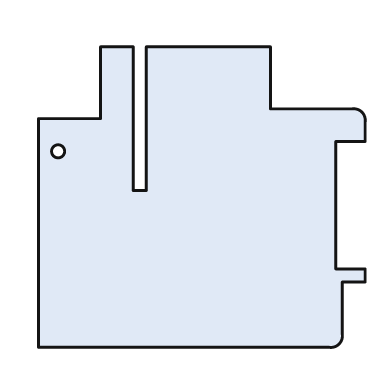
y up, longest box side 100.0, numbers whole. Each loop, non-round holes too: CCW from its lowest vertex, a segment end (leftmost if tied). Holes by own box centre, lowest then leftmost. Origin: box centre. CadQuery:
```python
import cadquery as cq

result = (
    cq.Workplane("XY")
    .moveTo(-50.0, -46.0)
    .lineTo(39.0, -46.0)
    .threePointArc((42.0, -45.0), (43.0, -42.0))
    .lineTo(43.0, -26.0)
    .lineTo(50.0, -26.0)
    .lineTo(50.0, -22.0)
    .lineTo(41.0, -22.0)
    .lineTo(41.0, 17.0)
    .lineTo(50.0, 17.0)
    .lineTo(50.0, 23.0)
    .threePointArc((49.0, 26.0), (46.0, 27.0))
    .lineTo(21.0, 27.0)
    .lineTo(21.0, 46.0)
    .lineTo(-17.0, 46.0)
    .lineTo(-17.0, 2.0)
    .lineTo(-21.0, 2.0)
    .lineTo(-21.0, 46.0)
    .lineTo(-31.0, 46.0)
    .lineTo(-31.0, 24.0)
    .lineTo(-50.0, 24.0)
    .close()
    .moveTo(-44.0, 14.0)
    .circle(2.0)
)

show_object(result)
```